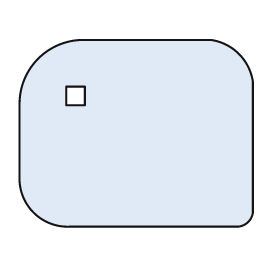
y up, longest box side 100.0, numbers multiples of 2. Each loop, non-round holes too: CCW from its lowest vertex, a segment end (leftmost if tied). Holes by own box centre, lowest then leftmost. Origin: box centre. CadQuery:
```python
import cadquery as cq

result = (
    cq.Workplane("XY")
    .moveTo(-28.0, -40.0)
    .lineTo(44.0, -40.0)
    .threePointArc((48.0, -38.0), (50.0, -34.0))
    .lineTo(50.0, 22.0)
    .threePointArc((44.0, 34.0), (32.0, 40.0))
    .lineTo(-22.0, 40.0)
    .threePointArc((-42.0, 32.0), (-50.0, 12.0))
    .lineTo(-50.0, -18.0)
    .threePointArc((-44.0, -34.0), (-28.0, -40.0))
    .close()
    .moveTo(-30.0, 12.0)
    .lineTo(-22.0, 12.0)
    .lineTo(-22.0, 20.0)
    .lineTo(-30.0, 20.0)
    .close()
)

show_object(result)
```